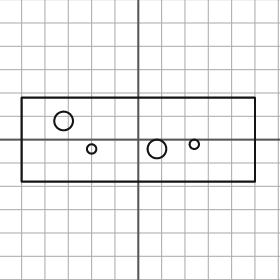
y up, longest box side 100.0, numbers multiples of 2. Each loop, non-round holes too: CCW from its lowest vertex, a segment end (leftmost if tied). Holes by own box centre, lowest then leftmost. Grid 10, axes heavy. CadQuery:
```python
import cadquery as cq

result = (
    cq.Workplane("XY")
    .moveTo(-50.0, -18.0)
    .lineTo(50.0, -18.0)
    .lineTo(50.0, 18.0)
    .lineTo(-50.0, 18.0)
    .close()
    .moveTo(-20.0, -4.0)
    .circle(2.0)
    .moveTo(8.0, -4.0)
    .circle(4.0)
    .moveTo(24.0, -2.0)
    .circle(2.0)
    .moveTo(-32.0, 8.0)
    .circle(4.0)
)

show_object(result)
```